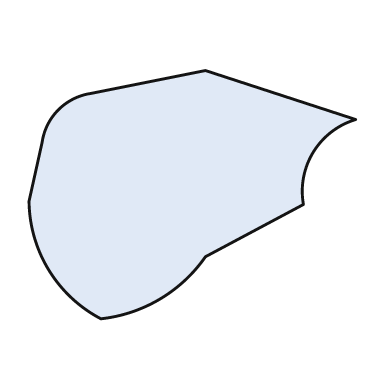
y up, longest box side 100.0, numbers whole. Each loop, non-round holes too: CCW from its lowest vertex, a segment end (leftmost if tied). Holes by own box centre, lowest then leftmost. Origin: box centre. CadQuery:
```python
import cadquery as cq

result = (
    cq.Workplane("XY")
    .moveTo(-28.0, -38.0)
    .threePointArc((-10.0, -32.0), (4.0, -19.0))
    .lineTo(34.0, -3.0)
    .threePointArc((37.0, 13.0), (50.0, 23.0))
    .lineTo(4.0, 38.0)
    .lineTo(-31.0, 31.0)
    .threePointArc((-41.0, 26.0), (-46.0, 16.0))
    .lineTo(-50.0, -2.0)
    .threePointArc((-44.0, -23.0), (-28.0, -38.0))
    .close()
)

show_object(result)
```